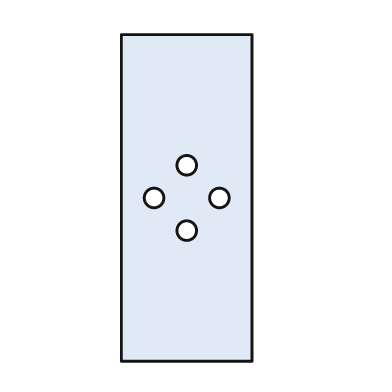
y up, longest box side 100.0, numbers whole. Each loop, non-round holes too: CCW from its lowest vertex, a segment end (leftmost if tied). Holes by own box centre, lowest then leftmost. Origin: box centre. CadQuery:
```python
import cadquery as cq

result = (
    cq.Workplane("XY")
    .moveTo(-20.0, -50.0)
    .lineTo(20.0, -50.0)
    .lineTo(20.0, 50.0)
    .lineTo(-20.0, 50.0)
    .close()
    .moveTo(0.0, -10.0)
    .circle(3.0)
    .moveTo(-10.0, 0.0)
    .circle(3.0)
    .moveTo(10.0, 0.0)
    .circle(3.0)
    .moveTo(0.0, 10.0)
    .circle(3.0)
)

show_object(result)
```